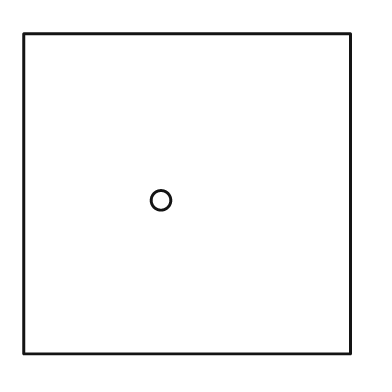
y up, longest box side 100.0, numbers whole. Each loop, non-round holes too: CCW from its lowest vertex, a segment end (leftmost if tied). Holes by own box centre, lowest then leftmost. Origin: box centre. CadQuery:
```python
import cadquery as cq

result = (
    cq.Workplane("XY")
    .moveTo(-50.0, -49.0)
    .lineTo(50.0, -49.0)
    .lineTo(50.0, 49.0)
    .lineTo(-50.0, 49.0)
    .close()
    .moveTo(-8.0, -2.0)
    .circle(3.0)
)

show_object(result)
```